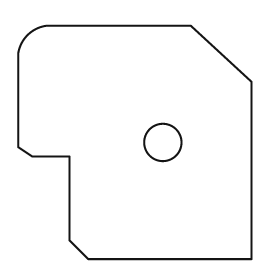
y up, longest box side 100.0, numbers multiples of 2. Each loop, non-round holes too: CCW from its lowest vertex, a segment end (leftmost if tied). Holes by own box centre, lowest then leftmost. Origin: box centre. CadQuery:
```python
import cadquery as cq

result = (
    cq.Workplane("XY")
    .moveTo(-20.0, -50.0)
    .lineTo(50.0, -50.0)
    .lineTo(50.0, 26.0)
    .lineTo(24.0, 50.0)
    .lineTo(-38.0, 50.0)
    .threePointArc((-46.0, 46.0), (-50.0, 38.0))
    .lineTo(-50.0, -2.0)
    .lineTo(-44.0, -6.0)
    .lineTo(-28.0, -6.0)
    .lineTo(-28.0, -42.0)
    .close()
    .moveTo(12.0, 0.0)
    .circle(8.0)
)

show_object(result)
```